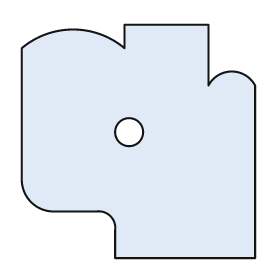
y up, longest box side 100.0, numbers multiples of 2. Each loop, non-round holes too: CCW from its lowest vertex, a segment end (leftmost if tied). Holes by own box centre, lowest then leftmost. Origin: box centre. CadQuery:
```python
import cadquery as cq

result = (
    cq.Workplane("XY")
    .moveTo(-10.0, -50.0)
    .lineTo(50.0, -50.0)
    .lineTo(50.0, 24.0)
    .threePointArc((40.0, 30.0), (30.0, 24.0))
    .lineTo(30.0, 50.0)
    .lineTo(-6.0, 50.0)
    .lineTo(-6.0, 40.0)
    .threePointArc((-28.0, 48.0), (-50.0, 40.0))
    .lineTo(-50.0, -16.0)
    .threePointArc((-46.0, -26.0), (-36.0, -30.0))
    .lineTo(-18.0, -30.0)
    .threePointArc((-12.0, -32.0), (-10.0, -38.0))
    .close()
    .moveTo(-4.0, 4.0)
    .circle(6.0)
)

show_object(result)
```